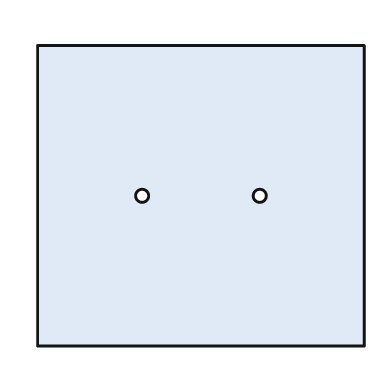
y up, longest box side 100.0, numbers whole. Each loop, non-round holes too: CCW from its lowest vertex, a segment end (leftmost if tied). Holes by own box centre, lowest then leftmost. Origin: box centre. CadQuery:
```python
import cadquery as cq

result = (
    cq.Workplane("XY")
    .moveTo(-50.0, -46.0)
    .lineTo(50.0, -46.0)
    .lineTo(50.0, 46.0)
    .lineTo(-50.0, 46.0)
    .close()
    .moveTo(-18.0, 0.0)
    .circle(2.0)
    .moveTo(18.0, 0.0)
    .circle(2.0)
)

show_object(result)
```